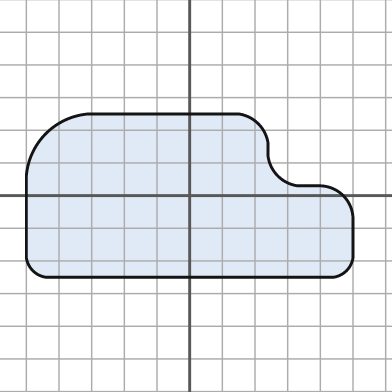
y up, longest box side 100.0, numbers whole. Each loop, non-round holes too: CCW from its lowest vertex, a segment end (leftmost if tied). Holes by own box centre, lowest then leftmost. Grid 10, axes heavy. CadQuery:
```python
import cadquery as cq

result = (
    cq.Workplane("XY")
    .moveTo(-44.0, -25.0)
    .lineTo(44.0, -25.0)
    .threePointArc((48.0, -23.0), (50.0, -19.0))
    .lineTo(50.0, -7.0)
    .threePointArc((47.0, 0.0), (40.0, 3.0))
    .lineTo(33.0, 3.0)
    .threePointArc((27.0, 6.0), (24.0, 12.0))
    .lineTo(24.0, 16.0)
    .threePointArc((21.0, 22.0), (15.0, 25.0))
    .lineTo(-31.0, 25.0)
    .threePointArc((-44.0, 19.0), (-50.0, 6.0))
    .lineTo(-50.0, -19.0)
    .threePointArc((-48.0, -23.0), (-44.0, -25.0))
    .close()
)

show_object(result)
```